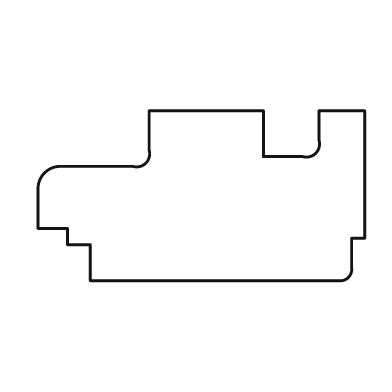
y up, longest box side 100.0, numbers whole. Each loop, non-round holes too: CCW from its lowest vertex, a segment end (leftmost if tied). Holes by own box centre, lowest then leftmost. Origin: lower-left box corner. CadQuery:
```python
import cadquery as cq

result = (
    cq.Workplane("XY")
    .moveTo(16.0, 0.0)
    .lineTo(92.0, 0.0)
    .threePointArc((95.0, 1.0), (96.0, 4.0))
    .lineTo(96.0, 13.0)
    .lineTo(100.0, 13.0)
    .lineTo(100.0, 52.0)
    .lineTo(86.0, 52.0)
    .lineTo(86.0, 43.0)
    .threePointArc((85.0, 39.0), (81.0, 38.0))
    .lineTo(69.0, 38.0)
    .lineTo(69.0, 52.0)
    .lineTo(34.0, 52.0)
    .lineTo(34.0, 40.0)
    .threePointArc((33.0, 36.0), (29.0, 35.0))
    .lineTo(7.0, 35.0)
    .threePointArc((2.0, 33.0), (0.0, 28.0))
    .lineTo(0.0, 16.0)
    .lineTo(9.0, 16.0)
    .lineTo(9.0, 11.0)
    .lineTo(16.0, 11.0)
    .close()
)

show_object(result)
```